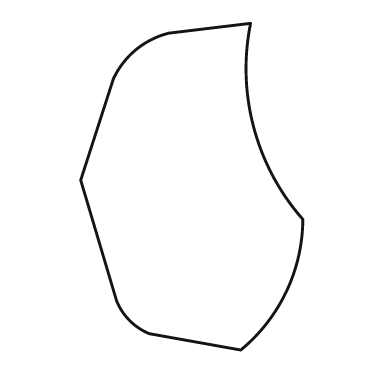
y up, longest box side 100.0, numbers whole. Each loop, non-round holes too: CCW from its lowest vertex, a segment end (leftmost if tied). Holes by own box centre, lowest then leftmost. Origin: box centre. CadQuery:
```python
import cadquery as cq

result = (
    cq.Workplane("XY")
    .moveTo(15.0, -50.0)
    .threePointArc((29.0, -32.0), (34.0, -10.0))
    .threePointArc((19.0, 18.0), (18.0, 50.0))
    .lineTo(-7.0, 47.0)
    .threePointArc((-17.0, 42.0), (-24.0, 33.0))
    .lineTo(-34.0, 2.0)
    .lineTo(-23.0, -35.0)
    .threePointArc((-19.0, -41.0), (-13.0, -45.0))
    .close()
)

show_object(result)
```